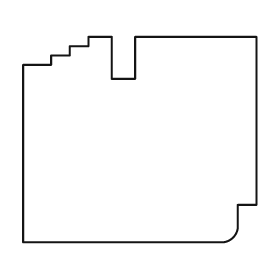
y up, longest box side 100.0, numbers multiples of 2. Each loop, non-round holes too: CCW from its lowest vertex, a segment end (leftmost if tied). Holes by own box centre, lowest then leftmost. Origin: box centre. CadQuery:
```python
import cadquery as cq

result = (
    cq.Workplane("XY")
    .moveTo(-50.0, -44.0)
    .lineTo(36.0, -44.0)
    .threePointArc((40.0, -42.0), (42.0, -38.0))
    .lineTo(42.0, -28.0)
    .lineTo(50.0, -28.0)
    .lineTo(50.0, 44.0)
    .lineTo(-2.0, 44.0)
    .lineTo(-2.0, 26.0)
    .lineTo(-12.0, 26.0)
    .lineTo(-12.0, 44.0)
    .lineTo(-22.0, 44.0)
    .lineTo(-22.0, 40.0)
    .lineTo(-30.0, 40.0)
    .lineTo(-30.0, 36.0)
    .lineTo(-38.0, 36.0)
    .lineTo(-38.0, 32.0)
    .lineTo(-50.0, 32.0)
    .close()
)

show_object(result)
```